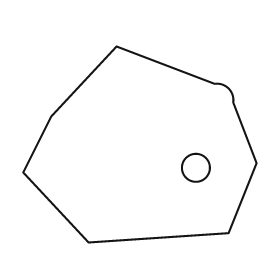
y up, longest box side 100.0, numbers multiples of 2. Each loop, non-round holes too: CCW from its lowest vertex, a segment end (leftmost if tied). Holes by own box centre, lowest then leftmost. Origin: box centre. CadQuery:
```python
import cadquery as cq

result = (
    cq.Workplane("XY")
    .moveTo(-22.0, -42.0)
    .lineTo(38.0, -38.0)
    .lineTo(50.0, -8.0)
    .lineTo(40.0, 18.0)
    .threePointArc((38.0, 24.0), (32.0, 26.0))
    .lineTo(-10.0, 42.0)
    .lineTo(-38.0, 12.0)
    .lineTo(-50.0, -12.0)
    .close()
    .moveTo(24.0, -10.0)
    .circle(6.0)
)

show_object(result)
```